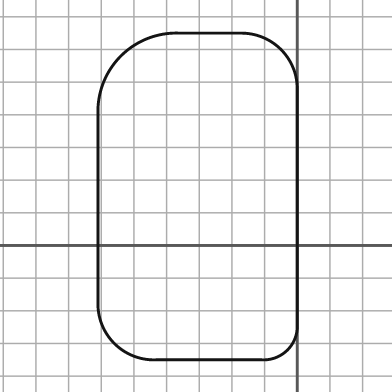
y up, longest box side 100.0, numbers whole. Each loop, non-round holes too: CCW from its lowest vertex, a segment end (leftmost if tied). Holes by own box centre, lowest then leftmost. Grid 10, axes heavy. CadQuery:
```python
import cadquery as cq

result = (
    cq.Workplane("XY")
    .moveTo(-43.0, -35.0)
    .lineTo(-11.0, -35.0)
    .threePointArc((-3.0, -32.0), (0.0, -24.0))
    .lineTo(0.0, 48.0)
    .threePointArc((-5.0, 60.0), (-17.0, 65.0))
    .lineTo(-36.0, 65.0)
    .threePointArc((-54.0, 58.0), (-61.0, 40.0))
    .lineTo(-61.0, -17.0)
    .threePointArc((-56.0, -30.0), (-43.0, -35.0))
    .close()
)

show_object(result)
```